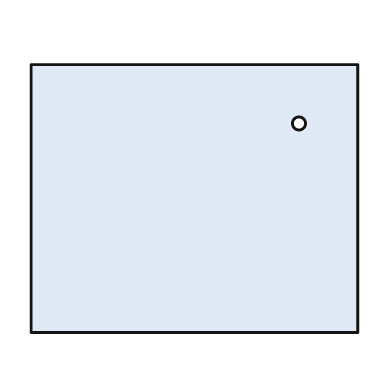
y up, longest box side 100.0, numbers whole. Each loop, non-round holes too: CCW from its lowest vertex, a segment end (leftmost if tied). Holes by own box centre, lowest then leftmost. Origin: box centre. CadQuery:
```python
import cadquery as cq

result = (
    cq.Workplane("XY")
    .moveTo(-50.0, -41.0)
    .lineTo(50.0, -41.0)
    .lineTo(50.0, 41.0)
    .lineTo(-50.0, 41.0)
    .close()
    .moveTo(32.0, 23.0)
    .circle(2.0)
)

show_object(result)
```